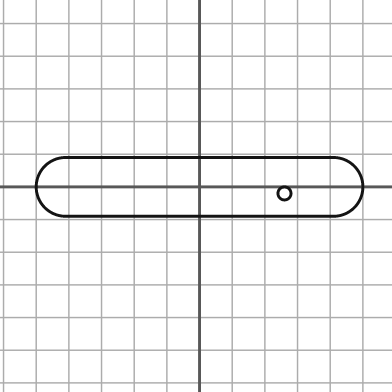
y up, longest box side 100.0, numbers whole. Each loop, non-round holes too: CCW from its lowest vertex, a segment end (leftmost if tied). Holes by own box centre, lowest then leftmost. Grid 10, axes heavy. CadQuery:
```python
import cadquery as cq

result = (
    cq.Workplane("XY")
    .moveTo(-41.0, -9.0)
    .lineTo(41.0, -9.0)
    .threePointArc((50.0, 0.0), (41.0, 9.0))
    .lineTo(-41.0, 9.0)
    .threePointArc((-50.0, 0.0), (-41.0, -9.0))
    .close()
    .moveTo(26.0, -2.0)
    .circle(2.0)
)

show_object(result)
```